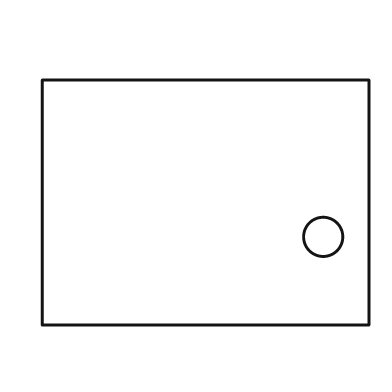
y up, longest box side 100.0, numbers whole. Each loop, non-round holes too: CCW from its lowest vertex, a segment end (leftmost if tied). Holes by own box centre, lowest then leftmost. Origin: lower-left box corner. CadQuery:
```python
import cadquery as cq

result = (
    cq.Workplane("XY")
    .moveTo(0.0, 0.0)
    .lineTo(100.0, 0.0)
    .lineTo(100.0, 75.0)
    .lineTo(0.0, 75.0)
    .close()
    .moveTo(86.0, 27.0)
    .circle(6.0)
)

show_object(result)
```